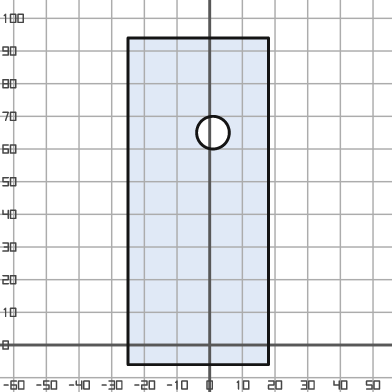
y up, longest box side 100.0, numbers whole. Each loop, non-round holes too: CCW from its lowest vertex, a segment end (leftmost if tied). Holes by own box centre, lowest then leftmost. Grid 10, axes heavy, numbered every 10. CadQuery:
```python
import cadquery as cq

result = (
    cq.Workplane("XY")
    .moveTo(-25.0, -6.0)
    .lineTo(18.0, -6.0)
    .lineTo(18.0, 94.0)
    .lineTo(-25.0, 94.0)
    .close()
    .moveTo(1.0, 65.0)
    .circle(5.0)
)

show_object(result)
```